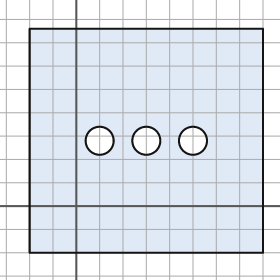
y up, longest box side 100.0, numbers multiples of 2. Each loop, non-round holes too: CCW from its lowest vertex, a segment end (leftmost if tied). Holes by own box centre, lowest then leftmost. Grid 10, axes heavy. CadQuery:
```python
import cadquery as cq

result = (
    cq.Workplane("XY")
    .moveTo(-20.0, -20.0)
    .lineTo(80.0, -20.0)
    .lineTo(80.0, 76.0)
    .lineTo(-20.0, 76.0)
    .close()
    .moveTo(10.0, 28.0)
    .circle(6.0)
    .moveTo(30.0, 28.0)
    .circle(6.0)
    .moveTo(50.0, 28.0)
    .circle(6.0)
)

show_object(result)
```